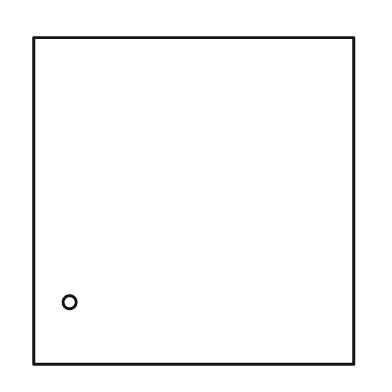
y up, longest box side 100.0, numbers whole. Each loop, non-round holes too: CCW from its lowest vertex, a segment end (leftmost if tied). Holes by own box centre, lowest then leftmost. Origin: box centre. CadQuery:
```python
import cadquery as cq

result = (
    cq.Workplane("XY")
    .moveTo(-49.0, -50.0)
    .lineTo(49.0, -50.0)
    .lineTo(49.0, 50.0)
    .lineTo(-49.0, 50.0)
    .close()
    .moveTo(-38.0, -31.0)
    .circle(2.0)
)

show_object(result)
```